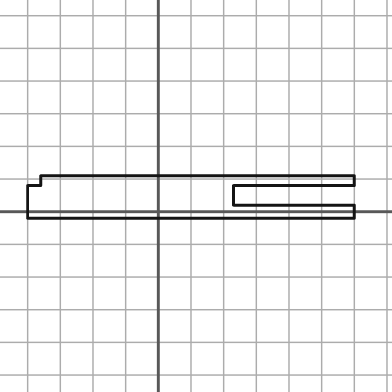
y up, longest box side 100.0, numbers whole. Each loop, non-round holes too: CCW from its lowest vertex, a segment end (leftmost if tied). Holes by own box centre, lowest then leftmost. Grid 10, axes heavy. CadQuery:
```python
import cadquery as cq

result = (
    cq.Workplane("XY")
    .moveTo(-40.0, -2.0)
    .lineTo(60.0, -2.0)
    .lineTo(60.0, 2.0)
    .lineTo(23.0, 2.0)
    .lineTo(23.0, 8.0)
    .lineTo(60.0, 8.0)
    .lineTo(60.0, 11.0)
    .lineTo(-36.0, 11.0)
    .lineTo(-36.0, 8.0)
    .lineTo(-40.0, 8.0)
    .close()
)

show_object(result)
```